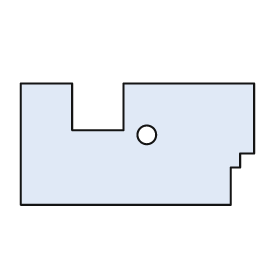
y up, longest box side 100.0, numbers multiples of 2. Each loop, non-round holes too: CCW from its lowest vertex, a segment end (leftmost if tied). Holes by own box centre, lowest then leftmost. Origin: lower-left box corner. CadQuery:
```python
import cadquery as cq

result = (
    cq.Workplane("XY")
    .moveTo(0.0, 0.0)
    .lineTo(90.0, 0.0)
    .lineTo(90.0, 16.0)
    .lineTo(94.0, 16.0)
    .lineTo(94.0, 22.0)
    .lineTo(100.0, 22.0)
    .lineTo(100.0, 52.0)
    .lineTo(44.0, 52.0)
    .lineTo(44.0, 32.0)
    .lineTo(22.0, 32.0)
    .lineTo(22.0, 52.0)
    .lineTo(0.0, 52.0)
    .close()
    .moveTo(54.0, 30.0)
    .circle(4.0)
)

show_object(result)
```